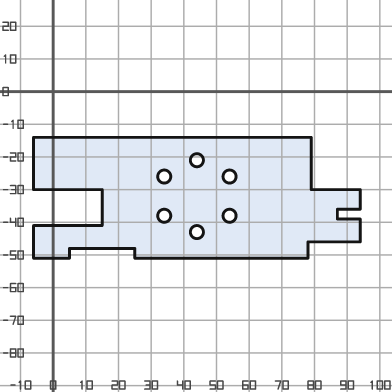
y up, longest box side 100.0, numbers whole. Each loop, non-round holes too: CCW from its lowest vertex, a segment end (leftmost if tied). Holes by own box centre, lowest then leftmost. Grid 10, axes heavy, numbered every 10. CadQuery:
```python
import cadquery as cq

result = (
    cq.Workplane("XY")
    .moveTo(-6.0, -51.0)
    .lineTo(5.0, -51.0)
    .lineTo(5.0, -48.0)
    .lineTo(25.0, -48.0)
    .lineTo(25.0, -51.0)
    .lineTo(78.0, -51.0)
    .lineTo(78.0, -46.0)
    .lineTo(94.0, -46.0)
    .lineTo(94.0, -39.0)
    .lineTo(87.0, -39.0)
    .lineTo(87.0, -36.0)
    .lineTo(94.0, -36.0)
    .lineTo(94.0, -30.0)
    .lineTo(79.0, -30.0)
    .lineTo(79.0, -14.0)
    .lineTo(-6.0, -14.0)
    .lineTo(-6.0, -30.0)
    .lineTo(15.0, -30.0)
    .lineTo(15.0, -41.0)
    .lineTo(-6.0, -41.0)
    .close()
    .moveTo(44.0, -43.0)
    .circle(2.0)
    .moveTo(34.0, -38.0)
    .circle(2.0)
    .moveTo(54.0, -38.0)
    .circle(2.0)
    .moveTo(34.0, -26.0)
    .circle(2.0)
    .moveTo(54.0, -26.0)
    .circle(2.0)
    .moveTo(44.0, -21.0)
    .circle(2.0)
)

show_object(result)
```